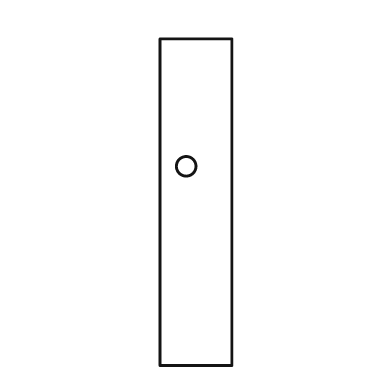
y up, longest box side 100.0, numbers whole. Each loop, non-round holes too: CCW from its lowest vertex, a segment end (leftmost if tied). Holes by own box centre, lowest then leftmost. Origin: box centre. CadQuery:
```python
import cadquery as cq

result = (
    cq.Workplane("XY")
    .moveTo(-11.0, -50.0)
    .lineTo(11.0, -50.0)
    .lineTo(11.0, 50.0)
    .lineTo(-11.0, 50.0)
    .close()
    .moveTo(-3.0, 11.0)
    .circle(3.0)
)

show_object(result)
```